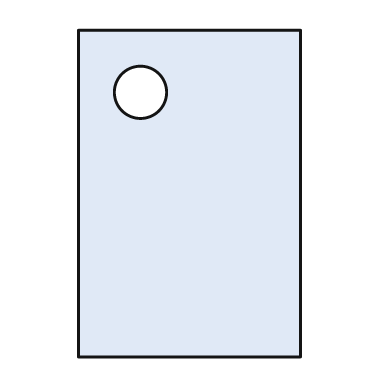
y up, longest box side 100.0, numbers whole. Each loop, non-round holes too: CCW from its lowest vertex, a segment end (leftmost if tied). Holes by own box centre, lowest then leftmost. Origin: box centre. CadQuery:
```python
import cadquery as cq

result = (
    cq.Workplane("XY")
    .moveTo(-34.0, -50.0)
    .lineTo(34.0, -50.0)
    .lineTo(34.0, 50.0)
    .lineTo(-34.0, 50.0)
    .close()
    .moveTo(-15.0, 31.0)
    .circle(8.0)
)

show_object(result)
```